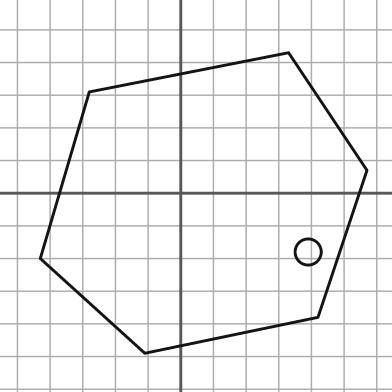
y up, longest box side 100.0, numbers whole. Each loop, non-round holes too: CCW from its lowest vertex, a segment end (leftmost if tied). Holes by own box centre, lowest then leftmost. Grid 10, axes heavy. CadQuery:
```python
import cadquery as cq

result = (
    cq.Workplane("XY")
    .moveTo(-11.0, -49.0)
    .lineTo(42.0, -38.0)
    .lineTo(57.0, 7.0)
    .lineTo(33.0, 43.0)
    .lineTo(-28.0, 31.0)
    .lineTo(-43.0, -20.0)
    .close()
    .moveTo(39.0, -18.0)
    .circle(4.0)
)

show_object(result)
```